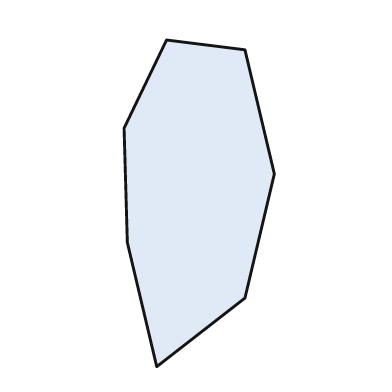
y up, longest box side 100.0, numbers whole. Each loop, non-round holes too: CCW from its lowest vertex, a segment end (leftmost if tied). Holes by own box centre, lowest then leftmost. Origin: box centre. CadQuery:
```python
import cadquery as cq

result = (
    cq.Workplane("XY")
    .moveTo(-13.0, -50.0)
    .lineTo(14.0, -29.0)
    .lineTo(23.0, 9.0)
    .lineTo(14.0, 47.0)
    .lineTo(-10.0, 50.0)
    .lineTo(-23.0, 23.0)
    .lineTo(-22.0, -12.0)
    .close()
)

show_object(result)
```